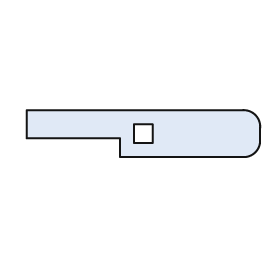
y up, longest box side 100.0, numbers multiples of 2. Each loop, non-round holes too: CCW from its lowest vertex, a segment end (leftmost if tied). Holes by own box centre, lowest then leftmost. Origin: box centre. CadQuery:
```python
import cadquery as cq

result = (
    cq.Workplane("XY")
    .moveTo(-10.0, -10.0)
    .lineTo(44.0, -10.0)
    .threePointArc((48.0, -8.0), (50.0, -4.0))
    .lineTo(50.0, 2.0)
    .threePointArc((48.0, 8.0), (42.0, 10.0))
    .lineTo(-50.0, 10.0)
    .lineTo(-50.0, -2.0)
    .lineTo(-10.0, -2.0)
    .close()
    .moveTo(-4.0, -4.0)
    .lineTo(4.0, -4.0)
    .lineTo(4.0, 4.0)
    .lineTo(-4.0, 4.0)
    .close()
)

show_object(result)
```